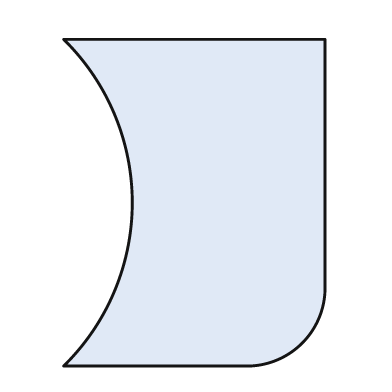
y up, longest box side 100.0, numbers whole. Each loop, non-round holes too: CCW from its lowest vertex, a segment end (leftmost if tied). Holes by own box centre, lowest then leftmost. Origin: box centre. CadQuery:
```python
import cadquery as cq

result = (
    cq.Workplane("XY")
    .moveTo(-40.0, -50.0)
    .lineTo(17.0, -50.0)
    .threePointArc((33.0, -43.0), (40.0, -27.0))
    .lineTo(40.0, 50.0)
    .lineTo(-40.0, 50.0)
    .threePointArc((-19.0, 0.0), (-40.0, -50.0))
    .close()
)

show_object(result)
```